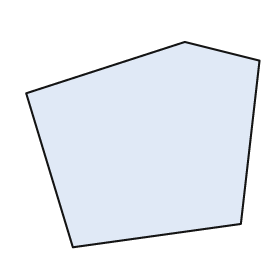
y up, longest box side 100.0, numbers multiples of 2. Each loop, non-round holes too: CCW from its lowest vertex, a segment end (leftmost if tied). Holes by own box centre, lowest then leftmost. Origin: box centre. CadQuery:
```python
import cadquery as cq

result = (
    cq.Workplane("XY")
    .moveTo(-30.0, -44.0)
    .lineTo(42.0, -34.0)
    .lineTo(50.0, 36.0)
    .lineTo(18.0, 44.0)
    .lineTo(-50.0, 22.0)
    .close()
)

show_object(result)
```